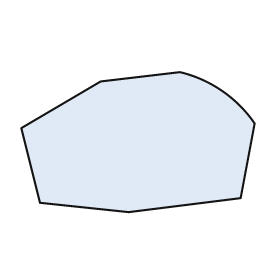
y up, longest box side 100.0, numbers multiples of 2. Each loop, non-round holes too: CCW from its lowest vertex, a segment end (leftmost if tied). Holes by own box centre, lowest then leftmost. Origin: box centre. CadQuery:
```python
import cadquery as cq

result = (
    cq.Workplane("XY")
    .moveTo(-4.0, -30.0)
    .lineTo(44.0, -24.0)
    .lineTo(50.0, 8.0)
    .threePointArc((36.0, 22.0), (18.0, 30.0))
    .lineTo(-16.0, 26.0)
    .lineTo(-50.0, 6.0)
    .lineTo(-42.0, -26.0)
    .close()
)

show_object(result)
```